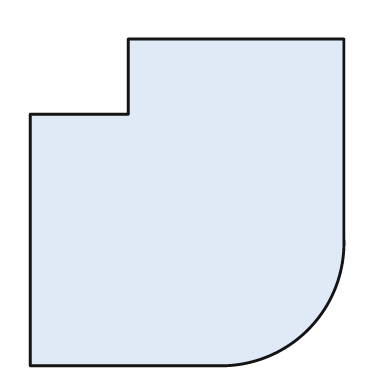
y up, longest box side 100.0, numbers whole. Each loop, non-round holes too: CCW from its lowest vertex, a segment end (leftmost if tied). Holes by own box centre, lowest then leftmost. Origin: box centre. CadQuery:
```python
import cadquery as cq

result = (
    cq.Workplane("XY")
    .moveTo(-48.0, -50.0)
    .lineTo(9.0, -50.0)
    .threePointArc((37.0, -39.0), (48.0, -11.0))
    .lineTo(48.0, 50.0)
    .lineTo(-18.0, 50.0)
    .lineTo(-18.0, 27.0)
    .lineTo(-48.0, 27.0)
    .close()
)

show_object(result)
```